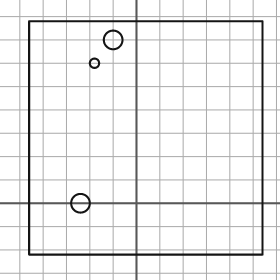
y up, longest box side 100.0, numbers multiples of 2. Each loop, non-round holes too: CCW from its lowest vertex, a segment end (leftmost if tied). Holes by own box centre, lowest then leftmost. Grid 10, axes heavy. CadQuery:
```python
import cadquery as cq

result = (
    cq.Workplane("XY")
    .moveTo(-46.0, -22.0)
    .lineTo(54.0, -22.0)
    .lineTo(54.0, 78.0)
    .lineTo(-46.0, 78.0)
    .close()
    .moveTo(-24.0, 0.0)
    .circle(4.0)
    .moveTo(-18.0, 60.0)
    .circle(2.0)
    .moveTo(-10.0, 70.0)
    .circle(4.0)
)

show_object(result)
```